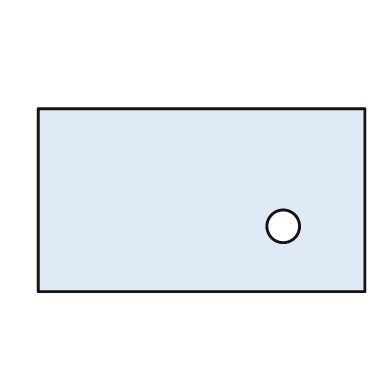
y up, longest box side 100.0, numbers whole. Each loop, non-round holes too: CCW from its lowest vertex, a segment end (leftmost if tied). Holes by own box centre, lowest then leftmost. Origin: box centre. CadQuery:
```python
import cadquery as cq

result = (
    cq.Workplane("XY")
    .moveTo(-50.0, -28.0)
    .lineTo(50.0, -28.0)
    .lineTo(50.0, 28.0)
    .lineTo(-50.0, 28.0)
    .close()
    .moveTo(25.0, -8.0)
    .circle(5.0)
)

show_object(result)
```